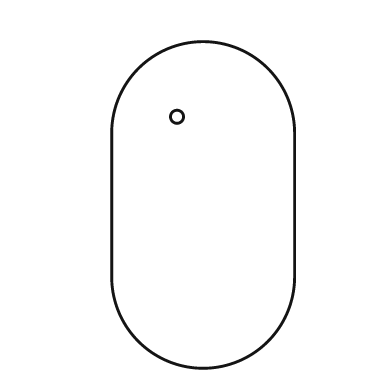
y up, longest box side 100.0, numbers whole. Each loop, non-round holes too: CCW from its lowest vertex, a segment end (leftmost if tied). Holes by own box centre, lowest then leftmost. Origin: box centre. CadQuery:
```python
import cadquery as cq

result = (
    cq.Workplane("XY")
    .moveTo(-28.0, -22.0)
    .threePointArc((0.0, -50.0), (28.0, -22.0))
    .lineTo(28.0, 22.0)
    .threePointArc((0.0, 50.0), (-28.0, 22.0))
    .close()
    .moveTo(-8.0, 27.0)
    .circle(2.0)
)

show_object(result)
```